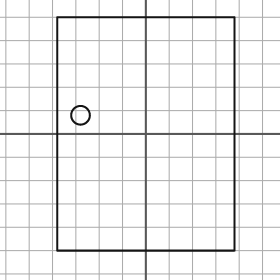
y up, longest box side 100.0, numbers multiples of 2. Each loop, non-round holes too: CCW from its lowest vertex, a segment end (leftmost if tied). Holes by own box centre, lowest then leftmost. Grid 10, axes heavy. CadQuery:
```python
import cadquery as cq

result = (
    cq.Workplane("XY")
    .moveTo(-38.0, -50.0)
    .lineTo(38.0, -50.0)
    .lineTo(38.0, 50.0)
    .lineTo(-38.0, 50.0)
    .close()
    .moveTo(-28.0, 8.0)
    .circle(4.0)
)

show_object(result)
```